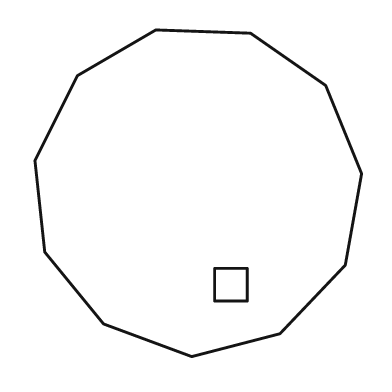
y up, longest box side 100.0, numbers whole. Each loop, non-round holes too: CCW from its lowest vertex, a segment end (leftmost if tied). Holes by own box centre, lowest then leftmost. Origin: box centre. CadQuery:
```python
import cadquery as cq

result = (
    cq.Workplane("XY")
    .moveTo(-2.0, -50.0)
    .lineTo(25.0, -43.0)
    .lineTo(45.0, -22.0)
    .lineTo(50.0, 6.0)
    .lineTo(39.0, 33.0)
    .lineTo(16.0, 49.0)
    .lineTo(-13.0, 50.0)
    .lineTo(-37.0, 36.0)
    .lineTo(-50.0, 10.0)
    .lineTo(-47.0, -18.0)
    .lineTo(-29.0, -40.0)
    .close()
    .moveTo(5.0, -33.0)
    .lineTo(15.0, -33.0)
    .lineTo(15.0, -23.0)
    .lineTo(5.0, -23.0)
    .close()
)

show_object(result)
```